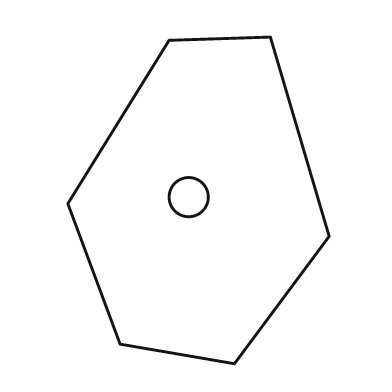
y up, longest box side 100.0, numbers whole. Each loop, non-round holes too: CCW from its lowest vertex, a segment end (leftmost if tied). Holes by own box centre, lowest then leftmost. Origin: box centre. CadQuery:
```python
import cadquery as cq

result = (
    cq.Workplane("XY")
    .moveTo(11.0, -50.0)
    .lineTo(40.0, -11.0)
    .lineTo(22.0, 50.0)
    .lineTo(-9.0, 49.0)
    .lineTo(-40.0, -1.0)
    .lineTo(-24.0, -44.0)
    .close()
    .moveTo(-3.0, 1.0)
    .circle(6.0)
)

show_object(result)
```